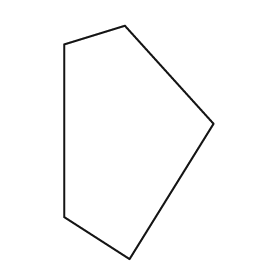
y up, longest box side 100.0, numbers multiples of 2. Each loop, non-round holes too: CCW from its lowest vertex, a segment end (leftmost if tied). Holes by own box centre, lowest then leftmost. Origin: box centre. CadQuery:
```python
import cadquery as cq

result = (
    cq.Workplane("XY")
    .moveTo(-4.0, -50.0)
    .lineTo(32.0, 8.0)
    .lineTo(-6.0, 50.0)
    .lineTo(-32.0, 42.0)
    .lineTo(-32.0, -32.0)
    .close()
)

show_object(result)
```